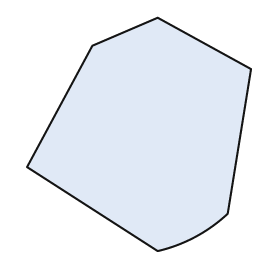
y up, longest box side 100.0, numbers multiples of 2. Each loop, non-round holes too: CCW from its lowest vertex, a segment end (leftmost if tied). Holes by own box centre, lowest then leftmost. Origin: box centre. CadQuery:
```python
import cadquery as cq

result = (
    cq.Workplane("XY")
    .moveTo(8.0, -50.0)
    .threePointArc((24.0, -44.0), (38.0, -34.0))
    .lineTo(48.0, 28.0)
    .lineTo(8.0, 50.0)
    .lineTo(-20.0, 38.0)
    .lineTo(-48.0, -14.0)
    .close()
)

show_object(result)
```